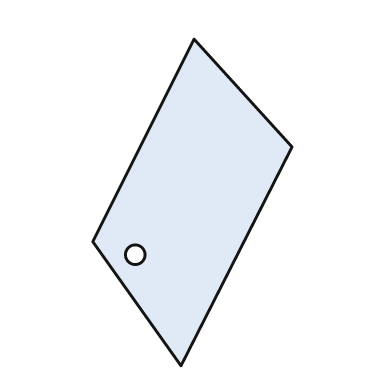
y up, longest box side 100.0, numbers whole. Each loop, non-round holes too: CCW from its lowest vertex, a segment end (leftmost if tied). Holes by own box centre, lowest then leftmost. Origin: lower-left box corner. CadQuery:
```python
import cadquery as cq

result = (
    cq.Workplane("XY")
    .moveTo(27.0, 0.0)
    .lineTo(61.0, 67.0)
    .lineTo(31.0, 100.0)
    .lineTo(0.0, 38.0)
    .close()
    .moveTo(13.0, 34.0)
    .circle(3.0)
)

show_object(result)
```